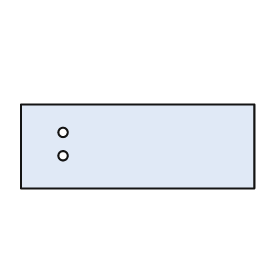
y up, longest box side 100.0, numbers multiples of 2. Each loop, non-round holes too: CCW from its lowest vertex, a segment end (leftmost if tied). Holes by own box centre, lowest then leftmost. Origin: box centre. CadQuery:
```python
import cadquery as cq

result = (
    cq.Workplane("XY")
    .moveTo(-50.0, -18.0)
    .lineTo(50.0, -18.0)
    .lineTo(50.0, 18.0)
    .lineTo(-50.0, 18.0)
    .close()
    .moveTo(-32.0, -4.0)
    .circle(2.0)
    .moveTo(-32.0, 6.0)
    .circle(2.0)
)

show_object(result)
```